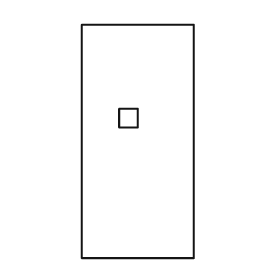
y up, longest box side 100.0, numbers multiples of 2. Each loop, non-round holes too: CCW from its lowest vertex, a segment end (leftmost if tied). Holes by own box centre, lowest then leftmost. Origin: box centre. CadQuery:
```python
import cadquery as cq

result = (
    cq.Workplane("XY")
    .moveTo(-24.0, -50.0)
    .lineTo(24.0, -50.0)
    .lineTo(24.0, 50.0)
    .lineTo(-24.0, 50.0)
    .close()
    .moveTo(-8.0, 6.0)
    .lineTo(0.0, 6.0)
    .lineTo(0.0, 14.0)
    .lineTo(-8.0, 14.0)
    .close()
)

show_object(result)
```